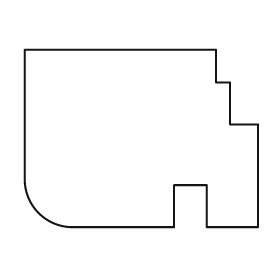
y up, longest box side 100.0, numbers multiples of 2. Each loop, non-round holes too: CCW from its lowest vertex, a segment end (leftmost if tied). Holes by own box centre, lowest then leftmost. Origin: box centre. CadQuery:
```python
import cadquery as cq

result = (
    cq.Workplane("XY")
    .moveTo(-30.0, -38.0)
    .lineTo(14.0, -38.0)
    .lineTo(14.0, -20.0)
    .lineTo(28.0, -20.0)
    .lineTo(28.0, -38.0)
    .lineTo(50.0, -38.0)
    .lineTo(50.0, 6.0)
    .lineTo(38.0, 6.0)
    .lineTo(38.0, 24.0)
    .lineTo(32.0, 24.0)
    .lineTo(32.0, 38.0)
    .lineTo(-50.0, 38.0)
    .lineTo(-50.0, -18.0)
    .threePointArc((-44.0, -32.0), (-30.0, -38.0))
    .close()
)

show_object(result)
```